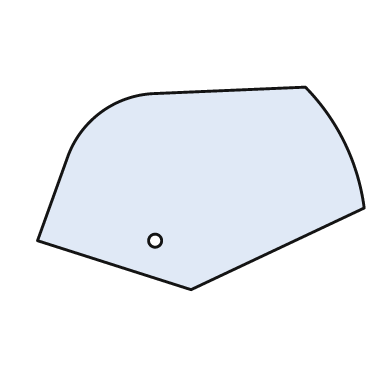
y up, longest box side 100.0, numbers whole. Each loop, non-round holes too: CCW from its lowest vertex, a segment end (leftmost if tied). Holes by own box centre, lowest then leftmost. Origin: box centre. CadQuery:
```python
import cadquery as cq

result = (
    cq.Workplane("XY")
    .moveTo(-3.0, -31.0)
    .lineTo(50.0, -6.0)
    .threePointArc((44.0, 14.0), (32.0, 31.0))
    .lineTo(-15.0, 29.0)
    .threePointArc((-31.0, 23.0), (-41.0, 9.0))
    .lineTo(-50.0, -16.0)
    .close()
    .moveTo(-14.0, -16.0)
    .circle(2.0)
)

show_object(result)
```